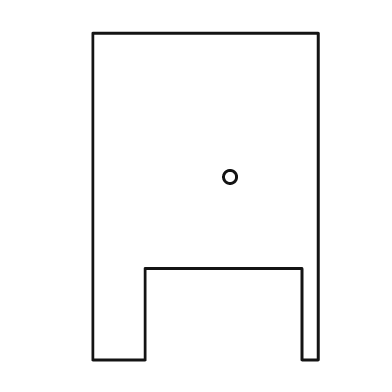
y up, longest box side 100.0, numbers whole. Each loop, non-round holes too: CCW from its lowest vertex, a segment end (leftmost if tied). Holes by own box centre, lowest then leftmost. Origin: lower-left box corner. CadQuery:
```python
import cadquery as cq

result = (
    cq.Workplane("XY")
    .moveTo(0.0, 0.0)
    .lineTo(16.0, 0.0)
    .lineTo(16.0, 28.0)
    .lineTo(64.0, 28.0)
    .lineTo(64.0, 0.0)
    .lineTo(69.0, 0.0)
    .lineTo(69.0, 100.0)
    .lineTo(0.0, 100.0)
    .close()
    .moveTo(42.0, 56.0)
    .circle(2.0)
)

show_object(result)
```